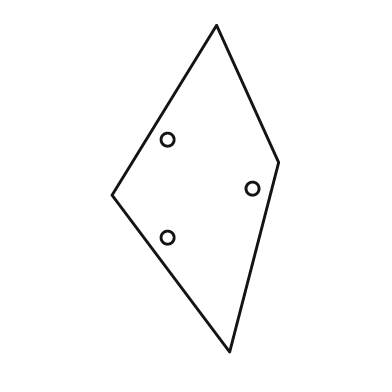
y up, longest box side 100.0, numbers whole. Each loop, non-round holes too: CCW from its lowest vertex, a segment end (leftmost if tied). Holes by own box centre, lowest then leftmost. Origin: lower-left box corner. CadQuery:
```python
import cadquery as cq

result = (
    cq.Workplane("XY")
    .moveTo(36.0, 0.0)
    .lineTo(51.0, 58.0)
    .lineTo(32.0, 100.0)
    .lineTo(0.0, 48.0)
    .close()
    .moveTo(17.0, 35.0)
    .circle(2.0)
    .moveTo(43.0, 50.0)
    .circle(2.0)
    .moveTo(17.0, 65.0)
    .circle(2.0)
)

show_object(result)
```